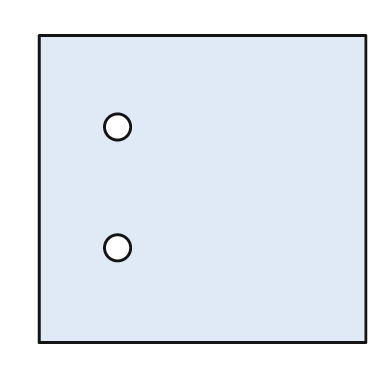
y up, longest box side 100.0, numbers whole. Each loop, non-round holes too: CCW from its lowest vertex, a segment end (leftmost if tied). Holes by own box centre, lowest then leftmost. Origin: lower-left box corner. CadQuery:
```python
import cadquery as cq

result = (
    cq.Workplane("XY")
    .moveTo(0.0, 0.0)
    .lineTo(100.0, 0.0)
    .lineTo(100.0, 94.0)
    .lineTo(0.0, 94.0)
    .close()
    .moveTo(24.0, 29.0)
    .circle(4.0)
    .moveTo(24.0, 66.0)
    .circle(4.0)
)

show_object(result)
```